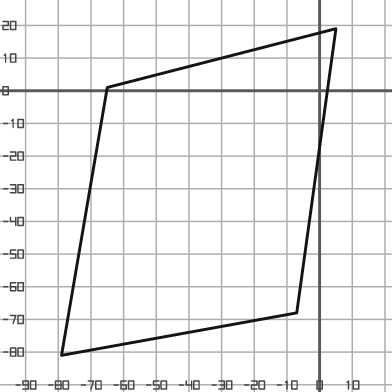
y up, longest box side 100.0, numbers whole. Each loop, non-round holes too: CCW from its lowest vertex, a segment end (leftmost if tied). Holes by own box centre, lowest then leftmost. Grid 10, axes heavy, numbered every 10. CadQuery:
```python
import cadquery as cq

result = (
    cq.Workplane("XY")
    .moveTo(-79.0, -81.0)
    .lineTo(-7.0, -68.0)
    .lineTo(5.0, 19.0)
    .lineTo(-65.0, 1.0)
    .close()
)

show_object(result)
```